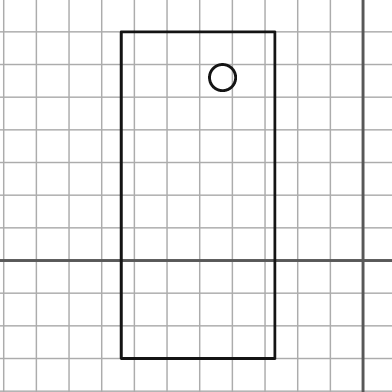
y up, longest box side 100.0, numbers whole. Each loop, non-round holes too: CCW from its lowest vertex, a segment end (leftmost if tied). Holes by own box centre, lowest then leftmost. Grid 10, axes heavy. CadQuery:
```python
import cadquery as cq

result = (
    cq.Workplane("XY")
    .moveTo(-74.0, -30.0)
    .lineTo(-27.0, -30.0)
    .lineTo(-27.0, 70.0)
    .lineTo(-74.0, 70.0)
    .close()
    .moveTo(-43.0, 56.0)
    .circle(4.0)
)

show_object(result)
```